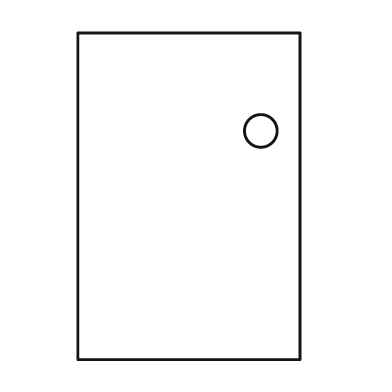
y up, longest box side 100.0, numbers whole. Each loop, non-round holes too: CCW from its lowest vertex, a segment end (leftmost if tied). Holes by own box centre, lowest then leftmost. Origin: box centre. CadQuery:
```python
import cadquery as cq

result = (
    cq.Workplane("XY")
    .moveTo(-34.0, -50.0)
    .lineTo(34.0, -50.0)
    .lineTo(34.0, 50.0)
    .lineTo(-34.0, 50.0)
    .close()
    .moveTo(22.0, 20.0)
    .circle(5.0)
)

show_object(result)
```